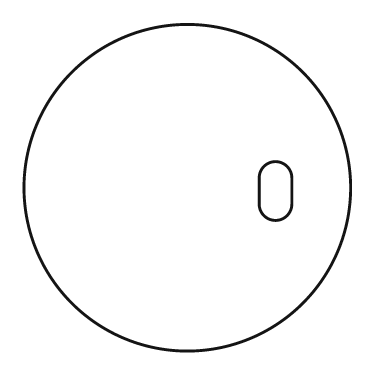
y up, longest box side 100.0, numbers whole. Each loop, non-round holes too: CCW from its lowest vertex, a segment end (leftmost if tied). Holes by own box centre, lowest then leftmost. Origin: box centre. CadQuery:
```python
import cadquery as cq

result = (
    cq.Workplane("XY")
    .moveTo(0.0, 0.0)
    .circle(50.0)
    .moveTo(22.0, -5.0)
    .threePointArc((27.0, -10.0), (32.0, -5.0))
    .lineTo(32.0, 3.0)
    .threePointArc((27.0, 8.0), (22.0, 3.0))
    .close()
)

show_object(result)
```